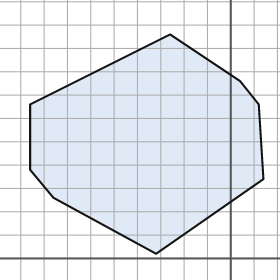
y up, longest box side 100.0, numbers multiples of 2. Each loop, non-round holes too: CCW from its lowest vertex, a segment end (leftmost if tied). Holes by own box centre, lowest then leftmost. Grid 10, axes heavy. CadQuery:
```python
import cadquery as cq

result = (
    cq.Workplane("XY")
    .moveTo(-32.0, 2.0)
    .lineTo(14.0, 34.0)
    .lineTo(12.0, 66.0)
    .lineTo(4.0, 76.0)
    .lineTo(-26.0, 96.0)
    .lineTo(-86.0, 66.0)
    .lineTo(-86.0, 38.0)
    .lineTo(-76.0, 26.0)
    .close()
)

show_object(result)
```